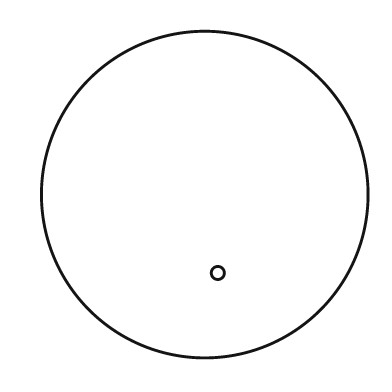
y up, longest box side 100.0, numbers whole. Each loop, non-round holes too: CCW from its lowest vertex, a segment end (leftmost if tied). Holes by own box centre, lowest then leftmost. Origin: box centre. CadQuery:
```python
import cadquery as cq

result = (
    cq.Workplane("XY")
    .moveTo(0.0, 0.0)
    .circle(50.0)
    .moveTo(4.0, -24.0)
    .circle(2.0)
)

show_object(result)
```